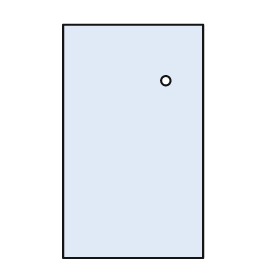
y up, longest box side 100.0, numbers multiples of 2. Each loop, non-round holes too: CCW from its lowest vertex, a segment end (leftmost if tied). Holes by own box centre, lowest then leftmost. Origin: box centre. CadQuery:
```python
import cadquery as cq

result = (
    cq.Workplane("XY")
    .moveTo(-30.0, -50.0)
    .lineTo(30.0, -50.0)
    .lineTo(30.0, 50.0)
    .lineTo(-30.0, 50.0)
    .close()
    .moveTo(14.0, 26.0)
    .circle(2.0)
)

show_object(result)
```